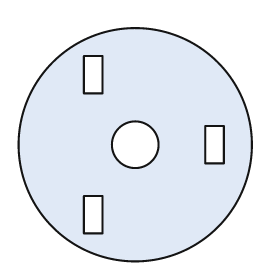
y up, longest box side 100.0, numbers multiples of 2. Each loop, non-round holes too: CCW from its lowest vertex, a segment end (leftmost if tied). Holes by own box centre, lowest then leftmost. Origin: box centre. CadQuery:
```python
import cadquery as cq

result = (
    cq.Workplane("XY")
    .moveTo(0.0, 0.0)
    .circle(50.0)
    .moveTo(-22.0, -38.0)
    .lineTo(-14.0, -38.0)
    .lineTo(-14.0, -22.0)
    .lineTo(-22.0, -22.0)
    .close()
    .moveTo(0.0, 0.0)
    .circle(10.0)
    .moveTo(30.0, -8.0)
    .lineTo(38.0, -8.0)
    .lineTo(38.0, 8.0)
    .lineTo(30.0, 8.0)
    .close()
    .moveTo(-22.0, 22.0)
    .lineTo(-14.0, 22.0)
    .lineTo(-14.0, 38.0)
    .lineTo(-22.0, 38.0)
    .close()
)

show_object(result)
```